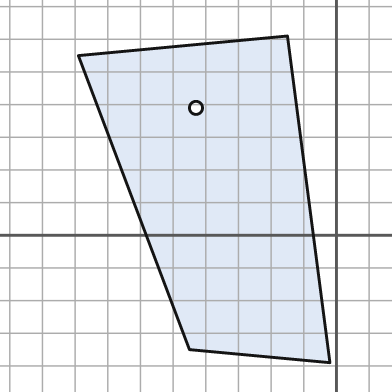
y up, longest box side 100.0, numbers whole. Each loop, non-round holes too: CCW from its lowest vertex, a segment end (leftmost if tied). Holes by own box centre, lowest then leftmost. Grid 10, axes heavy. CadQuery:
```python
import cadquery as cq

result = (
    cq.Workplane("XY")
    .moveTo(-2.0, -39.0)
    .lineTo(-15.0, 61.0)
    .lineTo(-79.0, 55.0)
    .lineTo(-45.0, -35.0)
    .close()
    .moveTo(-43.0, 39.0)
    .circle(2.0)
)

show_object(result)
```